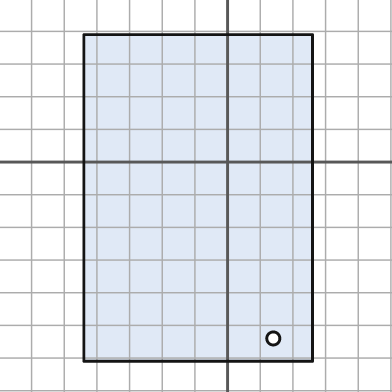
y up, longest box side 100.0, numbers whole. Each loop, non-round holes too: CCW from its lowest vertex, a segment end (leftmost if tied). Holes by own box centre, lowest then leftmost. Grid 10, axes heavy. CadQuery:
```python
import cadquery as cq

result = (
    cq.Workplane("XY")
    .moveTo(-44.0, -61.0)
    .lineTo(26.0, -61.0)
    .lineTo(26.0, 39.0)
    .lineTo(-44.0, 39.0)
    .close()
    .moveTo(14.0, -54.0)
    .circle(2.0)
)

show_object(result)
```